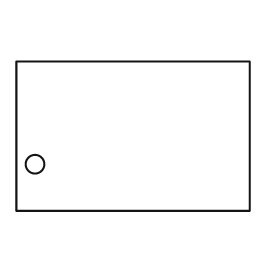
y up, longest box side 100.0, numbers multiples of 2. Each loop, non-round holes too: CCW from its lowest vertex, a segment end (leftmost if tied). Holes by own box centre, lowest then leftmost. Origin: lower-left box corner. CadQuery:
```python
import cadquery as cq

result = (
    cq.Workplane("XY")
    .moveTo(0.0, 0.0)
    .lineTo(100.0, 0.0)
    .lineTo(100.0, 64.0)
    .lineTo(0.0, 64.0)
    .close()
    .moveTo(8.0, 20.0)
    .circle(4.0)
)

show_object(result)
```